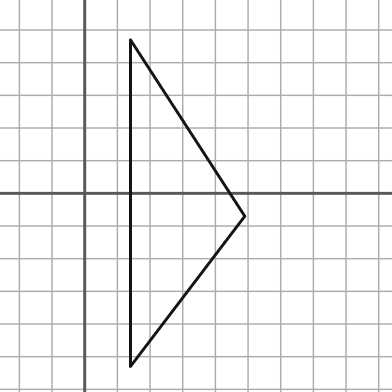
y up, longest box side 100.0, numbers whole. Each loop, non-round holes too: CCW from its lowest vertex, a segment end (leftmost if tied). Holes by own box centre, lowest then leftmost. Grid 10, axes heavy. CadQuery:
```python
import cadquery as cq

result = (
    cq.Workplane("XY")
    .moveTo(14.0, -53.0)
    .lineTo(49.0, -7.0)
    .lineTo(14.0, 47.0)
    .close()
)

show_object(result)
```